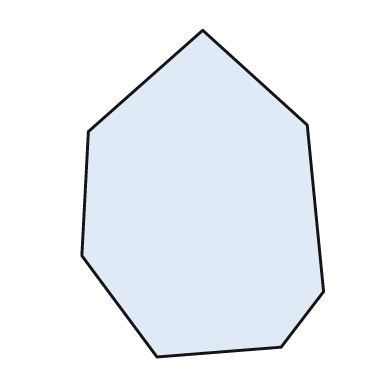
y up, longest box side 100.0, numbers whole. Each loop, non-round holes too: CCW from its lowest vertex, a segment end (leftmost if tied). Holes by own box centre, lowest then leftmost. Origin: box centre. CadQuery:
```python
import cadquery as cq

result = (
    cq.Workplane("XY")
    .moveTo(-14.0, -50.0)
    .lineTo(24.0, -47.0)
    .lineTo(37.0, -30.0)
    .lineTo(32.0, 21.0)
    .lineTo(0.0, 50.0)
    .lineTo(-35.0, 19.0)
    .lineTo(-37.0, -19.0)
    .close()
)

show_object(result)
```